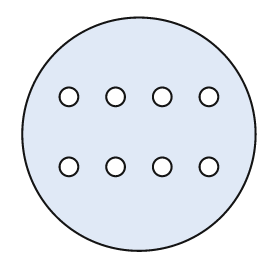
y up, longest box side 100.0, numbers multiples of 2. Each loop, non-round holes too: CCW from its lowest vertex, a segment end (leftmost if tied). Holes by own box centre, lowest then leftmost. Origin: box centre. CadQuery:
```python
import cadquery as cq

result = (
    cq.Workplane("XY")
    .moveTo(0.0, 0.0)
    .circle(50.0)
    .moveTo(-30.0, -14.0)
    .circle(4.0)
    .moveTo(-10.0, -14.0)
    .circle(4.0)
    .moveTo(10.0, -14.0)
    .circle(4.0)
    .moveTo(30.0, -14.0)
    .circle(4.0)
    .moveTo(-30.0, 16.0)
    .circle(4.0)
    .moveTo(-10.0, 16.0)
    .circle(4.0)
    .moveTo(10.0, 16.0)
    .circle(4.0)
    .moveTo(30.0, 16.0)
    .circle(4.0)
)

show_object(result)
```